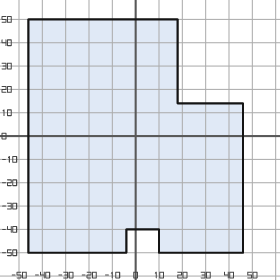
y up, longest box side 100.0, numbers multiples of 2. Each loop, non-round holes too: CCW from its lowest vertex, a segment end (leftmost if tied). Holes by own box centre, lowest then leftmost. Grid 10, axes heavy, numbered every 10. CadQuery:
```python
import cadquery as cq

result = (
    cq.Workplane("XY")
    .moveTo(-46.0, -50.0)
    .lineTo(-4.0, -50.0)
    .lineTo(-4.0, -40.0)
    .lineTo(10.0, -40.0)
    .lineTo(10.0, -50.0)
    .lineTo(46.0, -50.0)
    .lineTo(46.0, 14.0)
    .lineTo(18.0, 14.0)
    .lineTo(18.0, 50.0)
    .lineTo(-46.0, 50.0)
    .close()
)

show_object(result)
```